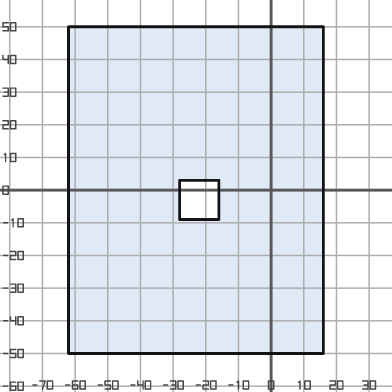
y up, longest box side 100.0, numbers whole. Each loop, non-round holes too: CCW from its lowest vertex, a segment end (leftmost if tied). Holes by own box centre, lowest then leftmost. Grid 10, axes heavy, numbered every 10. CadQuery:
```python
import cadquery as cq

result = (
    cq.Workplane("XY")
    .moveTo(-62.0, -50.0)
    .lineTo(16.0, -50.0)
    .lineTo(16.0, 50.0)
    .lineTo(-62.0, 50.0)
    .close()
    .moveTo(-28.0, -9.0)
    .lineTo(-16.0, -9.0)
    .lineTo(-16.0, 3.0)
    .lineTo(-28.0, 3.0)
    .close()
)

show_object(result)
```